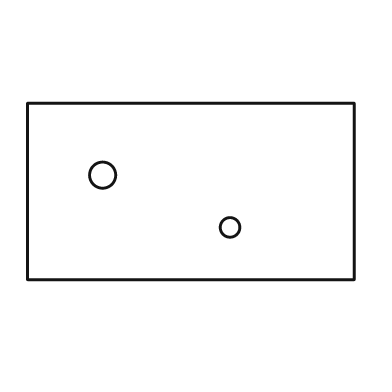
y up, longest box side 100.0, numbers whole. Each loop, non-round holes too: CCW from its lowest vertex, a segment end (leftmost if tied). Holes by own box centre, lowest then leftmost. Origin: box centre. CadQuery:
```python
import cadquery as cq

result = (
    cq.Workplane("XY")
    .moveTo(-50.0, -27.0)
    .lineTo(50.0, -27.0)
    .lineTo(50.0, 27.0)
    .lineTo(-50.0, 27.0)
    .close()
    .moveTo(12.0, -11.0)
    .circle(3.0)
    .moveTo(-27.0, 5.0)
    .circle(4.0)
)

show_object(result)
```